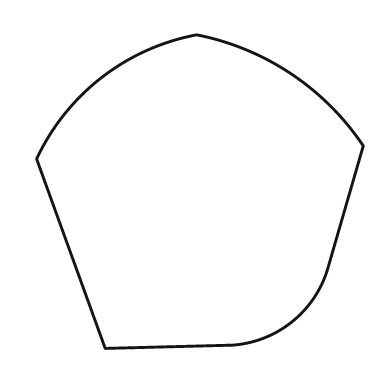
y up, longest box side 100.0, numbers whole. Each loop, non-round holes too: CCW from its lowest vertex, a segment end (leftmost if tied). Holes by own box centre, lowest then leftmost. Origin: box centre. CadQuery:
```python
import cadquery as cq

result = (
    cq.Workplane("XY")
    .moveTo(-29.0, -48.0)
    .lineTo(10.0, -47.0)
    .threePointArc((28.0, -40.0), (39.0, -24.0))
    .lineTo(50.0, 14.0)
    .threePointArc((28.0, 36.0), (-1.0, 48.0))
    .threePointArc((-30.0, 35.0), (-50.0, 10.0))
    .close()
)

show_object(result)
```